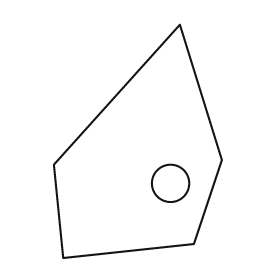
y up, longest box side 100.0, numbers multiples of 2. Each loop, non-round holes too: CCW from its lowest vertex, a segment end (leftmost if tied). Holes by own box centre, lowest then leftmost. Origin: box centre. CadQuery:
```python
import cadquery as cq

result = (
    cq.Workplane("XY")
    .moveTo(-32.0, -50.0)
    .lineTo(24.0, -44.0)
    .lineTo(36.0, -8.0)
    .lineTo(18.0, 50.0)
    .lineTo(-36.0, -10.0)
    .close()
    .moveTo(14.0, -18.0)
    .circle(8.0)
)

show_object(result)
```